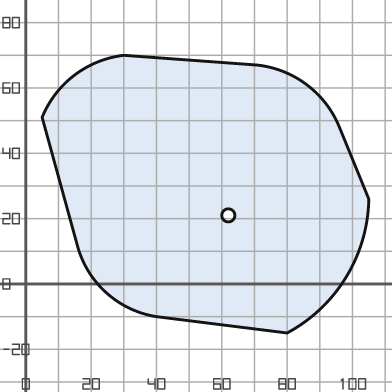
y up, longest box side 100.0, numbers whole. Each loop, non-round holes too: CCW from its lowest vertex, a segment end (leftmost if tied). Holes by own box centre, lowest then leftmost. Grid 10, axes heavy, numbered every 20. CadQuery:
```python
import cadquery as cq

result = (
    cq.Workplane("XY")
    .moveTo(80.0, -15.0)
    .threePointArc((98.0, 2.0), (105.0, 26.0))
    .lineTo(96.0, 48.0)
    .threePointArc((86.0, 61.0), (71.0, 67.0))
    .lineTo(30.0, 70.0)
    .threePointArc((15.0, 64.0), (5.0, 51.0))
    .lineTo(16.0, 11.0)
    .threePointArc((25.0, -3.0), (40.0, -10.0))
    .close()
    .moveTo(62.0, 21.0)
    .circle(2.0)
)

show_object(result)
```